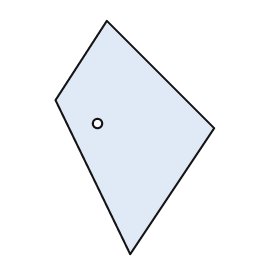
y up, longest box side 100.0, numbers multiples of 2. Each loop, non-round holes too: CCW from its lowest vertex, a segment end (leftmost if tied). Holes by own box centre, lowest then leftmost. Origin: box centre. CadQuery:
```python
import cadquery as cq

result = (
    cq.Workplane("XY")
    .moveTo(-2.0, -50.0)
    .lineTo(34.0, 4.0)
    .lineTo(-12.0, 50.0)
    .lineTo(-34.0, 16.0)
    .close()
    .moveTo(-16.0, 6.0)
    .circle(2.0)
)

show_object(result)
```